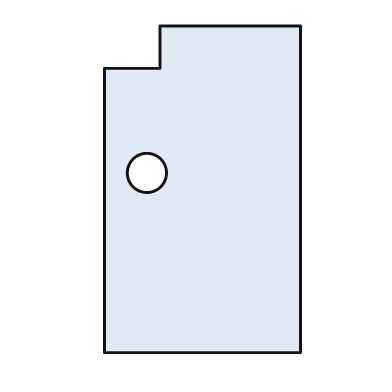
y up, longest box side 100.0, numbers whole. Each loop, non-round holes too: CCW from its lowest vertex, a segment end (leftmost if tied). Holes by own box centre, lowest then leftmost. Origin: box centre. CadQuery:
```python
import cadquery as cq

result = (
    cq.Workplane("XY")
    .moveTo(-30.0, -50.0)
    .lineTo(30.0, -50.0)
    .lineTo(30.0, 50.0)
    .lineTo(-13.0, 50.0)
    .lineTo(-13.0, 37.0)
    .lineTo(-30.0, 37.0)
    .close()
    .moveTo(-17.0, 5.0)
    .circle(6.0)
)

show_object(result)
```